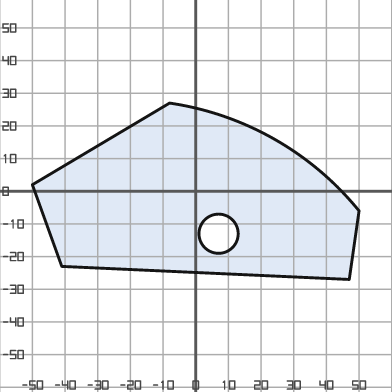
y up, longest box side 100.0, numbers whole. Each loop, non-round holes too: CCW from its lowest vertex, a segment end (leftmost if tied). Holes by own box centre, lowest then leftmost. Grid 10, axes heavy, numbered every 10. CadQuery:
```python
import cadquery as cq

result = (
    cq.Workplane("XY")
    .moveTo(47.0, -27.0)
    .lineTo(50.0, -6.0)
    .threePointArc((24.0, 16.0), (-8.0, 27.0))
    .lineTo(-50.0, 2.0)
    .lineTo(-41.0, -23.0)
    .close()
    .moveTo(7.0, -13.0)
    .circle(6.0)
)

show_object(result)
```